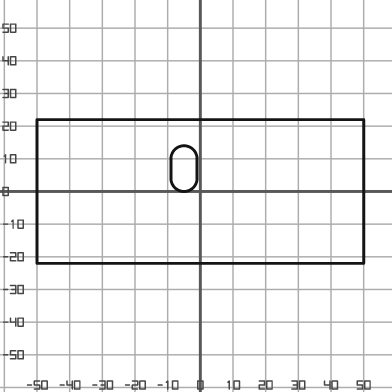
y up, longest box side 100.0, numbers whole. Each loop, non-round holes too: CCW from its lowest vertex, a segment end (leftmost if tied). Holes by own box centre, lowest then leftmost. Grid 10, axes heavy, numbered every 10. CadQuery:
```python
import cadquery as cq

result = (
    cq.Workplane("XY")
    .moveTo(-50.0, -22.0)
    .lineTo(50.0, -22.0)
    .lineTo(50.0, 22.0)
    .lineTo(-50.0, 22.0)
    .close()
    .moveTo(-9.0, 4.0)
    .threePointArc((-5.0, 0.0), (-1.0, 4.0))
    .lineTo(-1.0, 10.0)
    .threePointArc((-5.0, 14.0), (-9.0, 10.0))
    .close()
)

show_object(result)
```